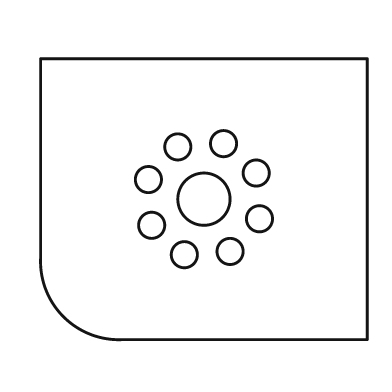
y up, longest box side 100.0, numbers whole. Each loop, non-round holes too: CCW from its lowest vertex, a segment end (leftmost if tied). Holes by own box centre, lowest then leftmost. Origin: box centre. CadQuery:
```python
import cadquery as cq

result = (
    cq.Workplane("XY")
    .moveTo(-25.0, -43.0)
    .lineTo(50.0, -43.0)
    .lineTo(50.0, 43.0)
    .lineTo(-50.0, 43.0)
    .lineTo(-50.0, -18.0)
    .threePointArc((-43.0, -36.0), (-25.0, -43.0))
    .close()
    .moveTo(-6.0, -17.0)
    .circle(4.0)
    .moveTo(8.0, -16.0)
    .circle(4.0)
    .moveTo(-16.0, -8.0)
    .circle(4.0)
    .moveTo(17.0, -6.0)
    .circle(4.0)
    .moveTo(0.0, 0.0)
    .circle(8.0)
    .moveTo(-17.0, 6.0)
    .circle(4.0)
    .moveTo(16.0, 8.0)
    .circle(4.0)
    .moveTo(-8.0, 16.0)
    .circle(4.0)
    .moveTo(6.0, 17.0)
    .circle(4.0)
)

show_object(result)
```